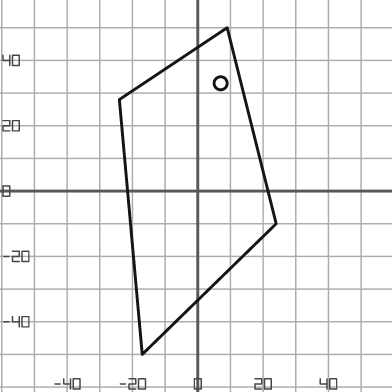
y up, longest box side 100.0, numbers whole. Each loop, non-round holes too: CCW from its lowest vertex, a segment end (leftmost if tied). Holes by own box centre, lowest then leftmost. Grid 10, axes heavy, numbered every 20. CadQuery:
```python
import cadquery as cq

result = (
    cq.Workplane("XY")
    .moveTo(-17.0, -50.0)
    .lineTo(24.0, -10.0)
    .lineTo(9.0, 50.0)
    .lineTo(-24.0, 28.0)
    .close()
    .moveTo(7.0, 33.0)
    .circle(2.0)
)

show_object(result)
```